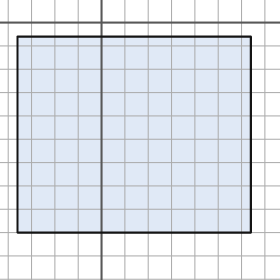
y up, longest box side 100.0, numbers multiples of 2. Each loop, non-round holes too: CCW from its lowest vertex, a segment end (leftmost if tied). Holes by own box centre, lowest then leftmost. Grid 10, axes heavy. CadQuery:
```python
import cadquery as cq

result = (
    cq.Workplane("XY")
    .moveTo(-36.0, -90.0)
    .lineTo(64.0, -90.0)
    .lineTo(64.0, -6.0)
    .lineTo(-36.0, -6.0)
    .close()
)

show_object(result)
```